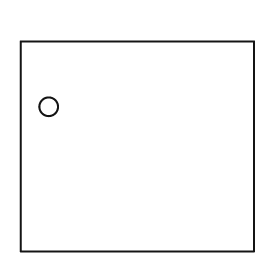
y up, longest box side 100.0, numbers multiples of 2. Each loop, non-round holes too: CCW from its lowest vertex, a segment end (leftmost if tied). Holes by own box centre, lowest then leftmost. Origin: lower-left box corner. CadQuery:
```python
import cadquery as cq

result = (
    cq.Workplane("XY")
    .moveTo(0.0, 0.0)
    .lineTo(100.0, 0.0)
    .lineTo(100.0, 90.0)
    .lineTo(0.0, 90.0)
    .close()
    .moveTo(12.0, 62.0)
    .circle(4.0)
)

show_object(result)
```